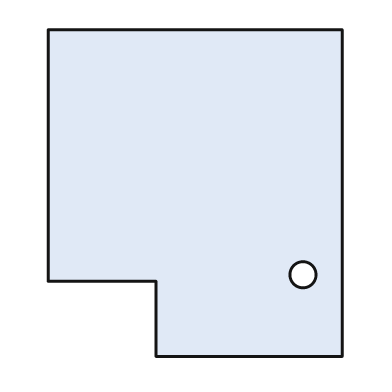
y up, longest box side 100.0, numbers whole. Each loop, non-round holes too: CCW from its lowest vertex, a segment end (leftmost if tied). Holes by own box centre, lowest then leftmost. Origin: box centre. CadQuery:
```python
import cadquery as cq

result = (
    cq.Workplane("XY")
    .moveTo(-12.0, -50.0)
    .lineTo(45.0, -50.0)
    .lineTo(45.0, 50.0)
    .lineTo(-45.0, 50.0)
    .lineTo(-45.0, -27.0)
    .lineTo(-12.0, -27.0)
    .close()
    .moveTo(33.0, -25.0)
    .circle(4.0)
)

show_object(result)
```